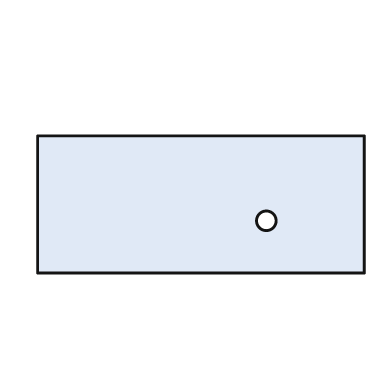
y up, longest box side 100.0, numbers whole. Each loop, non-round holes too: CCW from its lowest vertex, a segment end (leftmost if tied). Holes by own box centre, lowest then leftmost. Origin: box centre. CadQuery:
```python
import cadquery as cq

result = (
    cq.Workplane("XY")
    .moveTo(-50.0, -21.0)
    .lineTo(50.0, -21.0)
    .lineTo(50.0, 21.0)
    .lineTo(-50.0, 21.0)
    .close()
    .moveTo(20.0, -5.0)
    .circle(3.0)
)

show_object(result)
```